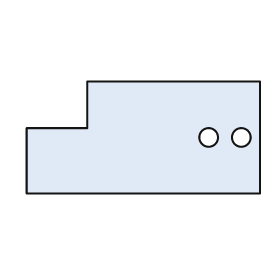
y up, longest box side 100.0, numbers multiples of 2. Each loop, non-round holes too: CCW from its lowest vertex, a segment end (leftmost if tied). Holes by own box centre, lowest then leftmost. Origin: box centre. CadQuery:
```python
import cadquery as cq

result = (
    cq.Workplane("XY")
    .moveTo(-50.0, -24.0)
    .lineTo(50.0, -24.0)
    .lineTo(50.0, 24.0)
    .lineTo(-24.0, 24.0)
    .lineTo(-24.0, 4.0)
    .lineTo(-50.0, 4.0)
    .close()
    .moveTo(28.0, 0.0)
    .circle(4.0)
    .moveTo(42.0, 0.0)
    .circle(4.0)
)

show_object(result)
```